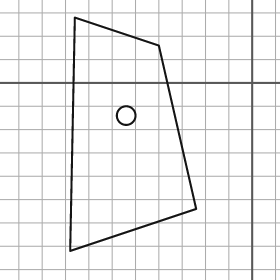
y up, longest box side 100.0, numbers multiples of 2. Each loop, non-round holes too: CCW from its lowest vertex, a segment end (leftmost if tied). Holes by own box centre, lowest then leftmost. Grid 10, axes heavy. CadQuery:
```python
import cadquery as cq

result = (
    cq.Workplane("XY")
    .moveTo(-78.0, -72.0)
    .lineTo(-24.0, -54.0)
    .lineTo(-40.0, 16.0)
    .lineTo(-76.0, 28.0)
    .close()
    .moveTo(-54.0, -14.0)
    .circle(4.0)
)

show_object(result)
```